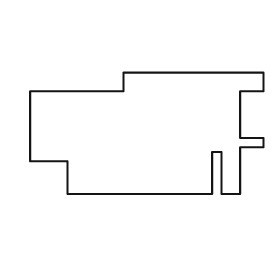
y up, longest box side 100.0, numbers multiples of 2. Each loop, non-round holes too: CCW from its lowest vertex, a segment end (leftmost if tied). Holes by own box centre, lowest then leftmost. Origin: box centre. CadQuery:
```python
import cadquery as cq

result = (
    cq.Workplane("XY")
    .moveTo(-34.0, -26.0)
    .lineTo(28.0, -26.0)
    .lineTo(28.0, -8.0)
    .lineTo(32.0, -8.0)
    .lineTo(32.0, -26.0)
    .lineTo(40.0, -26.0)
    .lineTo(40.0, -6.0)
    .lineTo(50.0, -6.0)
    .lineTo(50.0, -2.0)
    .lineTo(40.0, -2.0)
    .lineTo(40.0, 18.0)
    .lineTo(50.0, 18.0)
    .lineTo(50.0, 26.0)
    .lineTo(-10.0, 26.0)
    .lineTo(-10.0, 18.0)
    .lineTo(-50.0, 18.0)
    .lineTo(-50.0, -12.0)
    .lineTo(-34.0, -12.0)
    .close()
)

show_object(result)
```